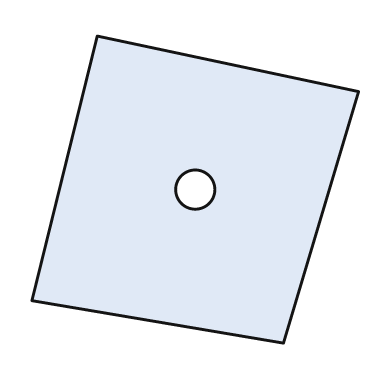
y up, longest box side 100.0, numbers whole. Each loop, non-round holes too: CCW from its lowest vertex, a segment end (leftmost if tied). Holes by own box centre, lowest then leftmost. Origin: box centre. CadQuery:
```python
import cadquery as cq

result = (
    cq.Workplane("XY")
    .moveTo(27.0, -47.0)
    .lineTo(50.0, 30.0)
    .lineTo(-30.0, 47.0)
    .lineTo(-50.0, -34.0)
    .close()
    .moveTo(0.0, 0.0)
    .circle(6.0)
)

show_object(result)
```